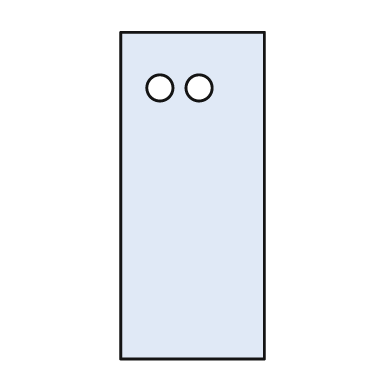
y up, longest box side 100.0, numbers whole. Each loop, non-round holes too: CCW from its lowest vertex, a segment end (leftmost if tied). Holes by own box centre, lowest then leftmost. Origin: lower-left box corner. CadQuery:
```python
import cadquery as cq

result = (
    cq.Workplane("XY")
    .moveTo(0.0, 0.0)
    .lineTo(44.0, 0.0)
    .lineTo(44.0, 100.0)
    .lineTo(0.0, 100.0)
    .close()
    .moveTo(12.0, 83.0)
    .circle(4.0)
    .moveTo(24.0, 83.0)
    .circle(4.0)
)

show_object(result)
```